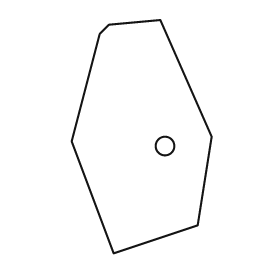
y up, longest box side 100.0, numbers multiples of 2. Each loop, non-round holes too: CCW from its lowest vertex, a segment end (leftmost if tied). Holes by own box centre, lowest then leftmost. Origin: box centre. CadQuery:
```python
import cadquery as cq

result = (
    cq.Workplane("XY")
    .moveTo(-12.0, -50.0)
    .lineTo(24.0, -38.0)
    .lineTo(30.0, 0.0)
    .lineTo(8.0, 50.0)
    .lineTo(-14.0, 48.0)
    .lineTo(-18.0, 44.0)
    .lineTo(-30.0, -2.0)
    .close()
    .moveTo(10.0, -4.0)
    .circle(4.0)
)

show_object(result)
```